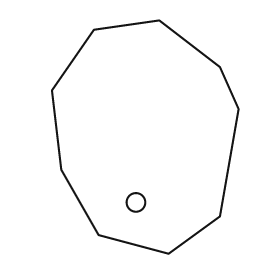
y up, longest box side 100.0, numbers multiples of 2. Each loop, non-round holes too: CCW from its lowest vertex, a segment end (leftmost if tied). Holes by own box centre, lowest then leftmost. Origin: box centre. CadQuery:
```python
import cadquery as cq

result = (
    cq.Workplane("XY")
    .moveTo(10.0, -50.0)
    .lineTo(32.0, -34.0)
    .lineTo(40.0, 12.0)
    .lineTo(32.0, 30.0)
    .lineTo(6.0, 50.0)
    .lineTo(-22.0, 46.0)
    .lineTo(-40.0, 20.0)
    .lineTo(-36.0, -14.0)
    .lineTo(-20.0, -42.0)
    .close()
    .moveTo(-4.0, -28.0)
    .circle(4.0)
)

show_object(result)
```